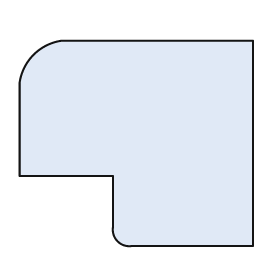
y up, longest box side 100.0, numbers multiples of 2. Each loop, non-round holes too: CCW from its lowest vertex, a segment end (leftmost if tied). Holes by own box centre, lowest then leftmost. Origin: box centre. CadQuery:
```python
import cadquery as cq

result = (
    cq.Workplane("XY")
    .moveTo(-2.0, -44.0)
    .lineTo(50.0, -44.0)
    .lineTo(50.0, 44.0)
    .lineTo(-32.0, 44.0)
    .threePointArc((-44.0, 38.0), (-50.0, 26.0))
    .lineTo(-50.0, -14.0)
    .lineTo(-10.0, -14.0)
    .lineTo(-10.0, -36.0)
    .threePointArc((-8.0, -42.0), (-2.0, -44.0))
    .close()
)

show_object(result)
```